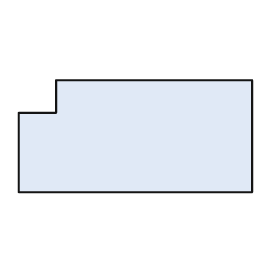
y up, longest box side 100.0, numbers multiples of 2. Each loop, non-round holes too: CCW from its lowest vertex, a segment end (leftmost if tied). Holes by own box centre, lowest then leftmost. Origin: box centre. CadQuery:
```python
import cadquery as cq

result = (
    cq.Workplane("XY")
    .moveTo(-50.0, -24.0)
    .lineTo(50.0, -24.0)
    .lineTo(50.0, 24.0)
    .lineTo(-34.0, 24.0)
    .lineTo(-34.0, 10.0)
    .lineTo(-50.0, 10.0)
    .close()
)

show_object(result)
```